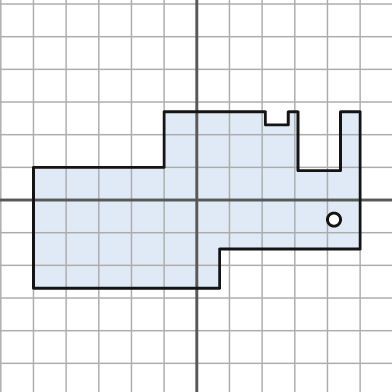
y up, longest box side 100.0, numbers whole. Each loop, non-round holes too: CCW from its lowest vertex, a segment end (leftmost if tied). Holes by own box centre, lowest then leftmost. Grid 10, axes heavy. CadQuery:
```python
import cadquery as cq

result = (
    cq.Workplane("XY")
    .moveTo(-50.0, -27.0)
    .lineTo(7.0, -27.0)
    .lineTo(7.0, -15.0)
    .lineTo(50.0, -15.0)
    .lineTo(50.0, 27.0)
    .lineTo(44.0, 27.0)
    .lineTo(44.0, 9.0)
    .lineTo(31.0, 9.0)
    .lineTo(31.0, 27.0)
    .lineTo(28.0, 27.0)
    .lineTo(28.0, 23.0)
    .lineTo(21.0, 23.0)
    .lineTo(21.0, 27.0)
    .lineTo(-10.0, 27.0)
    .lineTo(-10.0, 10.0)
    .lineTo(-50.0, 10.0)
    .close()
    .moveTo(42.0, -6.0)
    .circle(2.0)
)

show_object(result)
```